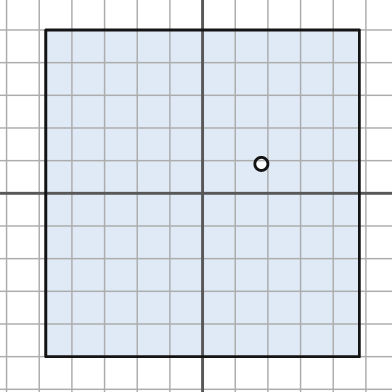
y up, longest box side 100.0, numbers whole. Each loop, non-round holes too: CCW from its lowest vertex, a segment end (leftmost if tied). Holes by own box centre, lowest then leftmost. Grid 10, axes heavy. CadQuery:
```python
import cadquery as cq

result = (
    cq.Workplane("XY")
    .moveTo(-48.0, -50.0)
    .lineTo(48.0, -50.0)
    .lineTo(48.0, 50.0)
    .lineTo(-48.0, 50.0)
    .close()
    .moveTo(18.0, 9.0)
    .circle(2.0)
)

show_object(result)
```